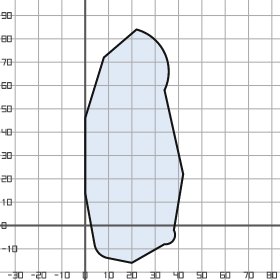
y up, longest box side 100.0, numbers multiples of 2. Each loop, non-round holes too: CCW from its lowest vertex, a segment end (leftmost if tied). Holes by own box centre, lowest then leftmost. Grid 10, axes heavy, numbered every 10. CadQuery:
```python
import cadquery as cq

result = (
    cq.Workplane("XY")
    .moveTo(20.0, -16.0)
    .lineTo(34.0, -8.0)
    .threePointArc((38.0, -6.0), (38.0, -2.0))
    .lineTo(42.0, 22.0)
    .lineTo(34.0, 58.0)
    .threePointArc((34.0, 74.0), (22.0, 84.0))
    .lineTo(8.0, 72.0)
    .lineTo(0.0, 46.0)
    .lineTo(0.0, 14.0)
    .lineTo(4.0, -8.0)
    .threePointArc((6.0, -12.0), (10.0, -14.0))
    .close()
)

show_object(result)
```